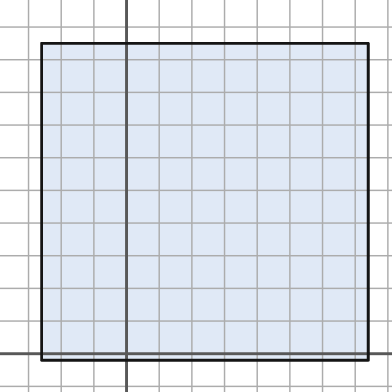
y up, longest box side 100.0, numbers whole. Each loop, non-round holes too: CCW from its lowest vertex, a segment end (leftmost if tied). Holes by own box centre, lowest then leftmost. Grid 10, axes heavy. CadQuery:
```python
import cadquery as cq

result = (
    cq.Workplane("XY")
    .moveTo(-26.0, -2.0)
    .lineTo(74.0, -2.0)
    .lineTo(74.0, 95.0)
    .lineTo(-26.0, 95.0)
    .close()
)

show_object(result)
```